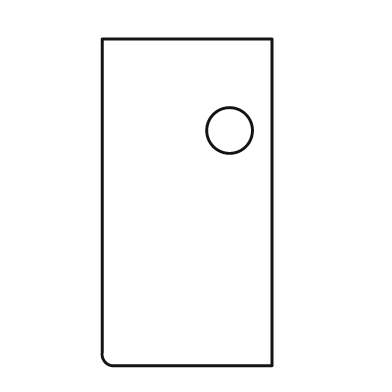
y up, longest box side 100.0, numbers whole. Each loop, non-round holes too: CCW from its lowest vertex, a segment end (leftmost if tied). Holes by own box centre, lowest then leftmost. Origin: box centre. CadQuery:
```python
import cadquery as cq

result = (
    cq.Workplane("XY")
    .moveTo(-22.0, -50.0)
    .lineTo(26.0, -50.0)
    .lineTo(26.0, 50.0)
    .lineTo(-26.0, 50.0)
    .lineTo(-26.0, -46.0)
    .threePointArc((-25.0, -49.0), (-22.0, -50.0))
    .close()
    .moveTo(13.0, 22.0)
    .circle(7.0)
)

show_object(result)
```